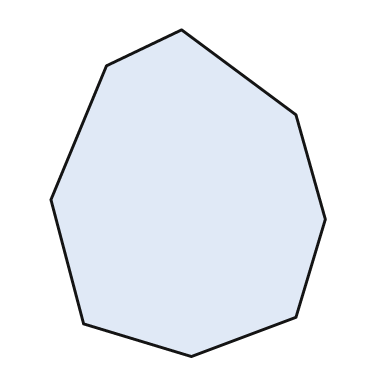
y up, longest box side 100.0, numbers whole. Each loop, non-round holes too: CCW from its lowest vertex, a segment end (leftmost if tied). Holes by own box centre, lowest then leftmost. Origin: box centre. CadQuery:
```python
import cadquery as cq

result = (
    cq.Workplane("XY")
    .moveTo(1.0, -50.0)
    .lineTo(33.0, -38.0)
    .lineTo(42.0, -8.0)
    .lineTo(33.0, 24.0)
    .lineTo(-2.0, 50.0)
    .lineTo(-25.0, 39.0)
    .lineTo(-42.0, -2.0)
    .lineTo(-32.0, -40.0)
    .close()
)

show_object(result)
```